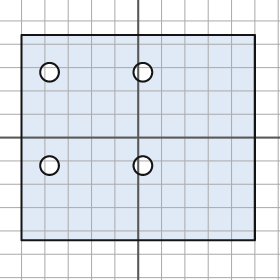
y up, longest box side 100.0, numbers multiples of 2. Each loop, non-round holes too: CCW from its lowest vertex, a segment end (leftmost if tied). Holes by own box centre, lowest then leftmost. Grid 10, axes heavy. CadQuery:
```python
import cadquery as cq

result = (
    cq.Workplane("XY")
    .moveTo(-50.0, -44.0)
    .lineTo(50.0, -44.0)
    .lineTo(50.0, 44.0)
    .lineTo(-50.0, 44.0)
    .close()
    .moveTo(-38.0, -12.0)
    .circle(4.0)
    .moveTo(2.0, -12.0)
    .circle(4.0)
    .moveTo(-38.0, 28.0)
    .circle(4.0)
    .moveTo(2.0, 28.0)
    .circle(4.0)
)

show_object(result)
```